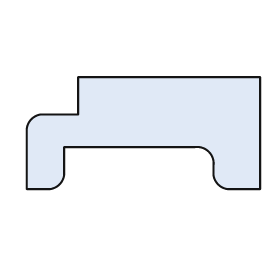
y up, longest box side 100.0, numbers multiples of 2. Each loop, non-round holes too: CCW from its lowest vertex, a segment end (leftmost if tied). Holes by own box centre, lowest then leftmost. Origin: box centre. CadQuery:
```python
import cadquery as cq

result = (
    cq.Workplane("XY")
    .moveTo(-50.0, -24.0)
    .lineTo(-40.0, -24.0)
    .threePointArc((-36.0, -22.0), (-34.0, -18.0))
    .lineTo(-34.0, -6.0)
    .lineTo(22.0, -6.0)
    .threePointArc((28.0, -8.0), (30.0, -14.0))
    .lineTo(30.0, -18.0)
    .threePointArc((32.0, -22.0), (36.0, -24.0))
    .lineTo(50.0, -24.0)
    .lineTo(50.0, 24.0)
    .lineTo(-28.0, 24.0)
    .lineTo(-28.0, 8.0)
    .lineTo(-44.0, 8.0)
    .threePointArc((-48.0, 6.0), (-50.0, 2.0))
    .close()
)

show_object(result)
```